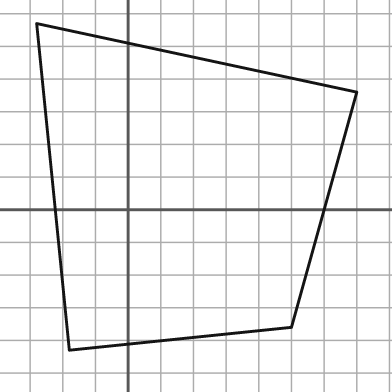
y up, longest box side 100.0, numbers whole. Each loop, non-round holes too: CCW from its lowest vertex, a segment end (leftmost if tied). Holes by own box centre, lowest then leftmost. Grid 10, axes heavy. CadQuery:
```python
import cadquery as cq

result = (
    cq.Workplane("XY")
    .moveTo(-18.0, -43.0)
    .lineTo(50.0, -36.0)
    .lineTo(70.0, 36.0)
    .lineTo(-28.0, 57.0)
    .close()
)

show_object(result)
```